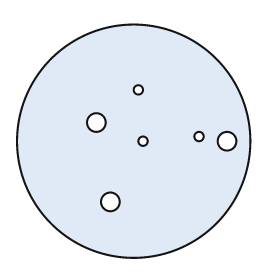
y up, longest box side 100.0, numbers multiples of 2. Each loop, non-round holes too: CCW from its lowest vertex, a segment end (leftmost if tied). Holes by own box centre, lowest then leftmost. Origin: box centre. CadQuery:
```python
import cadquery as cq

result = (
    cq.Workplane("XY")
    .moveTo(0.0, 0.0)
    .circle(50.0)
    .moveTo(-10.0, -26.0)
    .circle(4.0)
    .moveTo(4.0, 0.0)
    .circle(2.0)
    .moveTo(40.0, 0.0)
    .circle(4.0)
    .moveTo(28.0, 2.0)
    .circle(2.0)
    .moveTo(-16.0, 8.0)
    .circle(4.0)
    .moveTo(2.0, 22.0)
    .circle(2.0)
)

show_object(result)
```